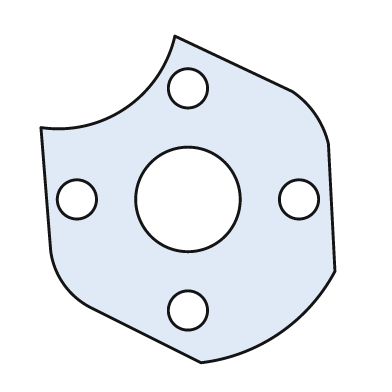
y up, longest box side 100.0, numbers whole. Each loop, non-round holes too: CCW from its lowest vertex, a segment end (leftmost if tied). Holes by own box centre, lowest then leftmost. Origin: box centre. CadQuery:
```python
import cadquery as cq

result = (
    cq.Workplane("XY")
    .moveTo(4.0, -50.0)
    .threePointArc((28.0, -41.0), (45.0, -22.0))
    .lineTo(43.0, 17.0)
    .threePointArc((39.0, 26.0), (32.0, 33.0))
    .lineTo(-4.0, 50.0)
    .threePointArc((-19.0, 28.0), (-45.0, 22.0))
    .lineTo(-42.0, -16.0)
    .threePointArc((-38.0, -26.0), (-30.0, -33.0))
    .close()
    .moveTo(0.0, -34.0)
    .circle(6.0)
    .moveTo(-34.0, 0.0)
    .circle(6.0)
    .moveTo(0.0, 0.0)
    .circle(16.0)
    .moveTo(34.0, 0.0)
    .circle(6.0)
    .moveTo(0.0, 34.0)
    .circle(6.0)
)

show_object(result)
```